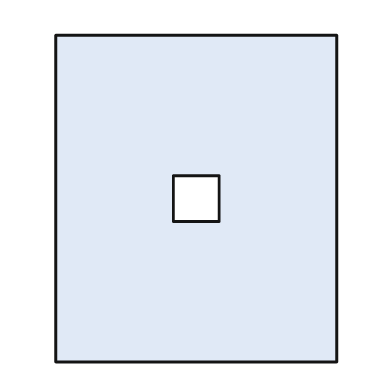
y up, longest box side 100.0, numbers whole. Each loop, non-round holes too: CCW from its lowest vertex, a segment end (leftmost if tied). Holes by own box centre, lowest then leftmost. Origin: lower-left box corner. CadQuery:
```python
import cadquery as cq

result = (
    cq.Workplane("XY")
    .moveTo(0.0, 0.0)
    .lineTo(86.0, 0.0)
    .lineTo(86.0, 100.0)
    .lineTo(0.0, 100.0)
    .close()
    .moveTo(36.0, 43.0)
    .lineTo(50.0, 43.0)
    .lineTo(50.0, 57.0)
    .lineTo(36.0, 57.0)
    .close()
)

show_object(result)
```